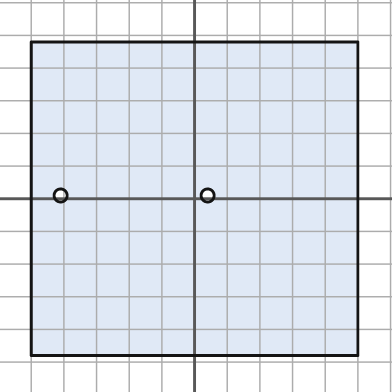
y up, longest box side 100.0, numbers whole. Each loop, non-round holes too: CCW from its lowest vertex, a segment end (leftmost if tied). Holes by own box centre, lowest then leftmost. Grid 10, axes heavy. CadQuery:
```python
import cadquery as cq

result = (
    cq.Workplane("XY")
    .moveTo(-50.0, -48.0)
    .lineTo(50.0, -48.0)
    .lineTo(50.0, 48.0)
    .lineTo(-50.0, 48.0)
    .close()
    .moveTo(-41.0, 1.0)
    .circle(2.0)
    .moveTo(4.0, 1.0)
    .circle(2.0)
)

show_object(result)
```